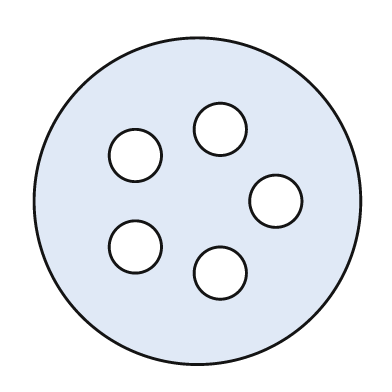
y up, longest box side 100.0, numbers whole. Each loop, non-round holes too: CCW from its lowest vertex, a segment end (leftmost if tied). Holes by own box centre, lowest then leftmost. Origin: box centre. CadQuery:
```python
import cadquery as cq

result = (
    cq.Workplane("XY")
    .moveTo(0.0, 0.0)
    .circle(50.0)
    .moveTo(7.0, -22.0)
    .circle(8.0)
    .moveTo(-19.0, -14.0)
    .circle(8.0)
    .moveTo(24.0, 0.0)
    .circle(8.0)
    .moveTo(-19.0, 14.0)
    .circle(8.0)
    .moveTo(7.0, 22.0)
    .circle(8.0)
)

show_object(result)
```